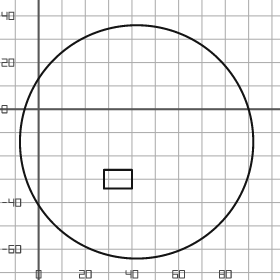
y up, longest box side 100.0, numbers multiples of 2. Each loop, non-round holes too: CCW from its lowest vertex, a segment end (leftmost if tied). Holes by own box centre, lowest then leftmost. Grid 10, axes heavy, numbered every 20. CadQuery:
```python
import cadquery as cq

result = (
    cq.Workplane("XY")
    .moveTo(42.0, -14.0)
    .circle(50.0)
    .moveTo(28.0, -34.0)
    .lineTo(40.0, -34.0)
    .lineTo(40.0, -26.0)
    .lineTo(28.0, -26.0)
    .close()
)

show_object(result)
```